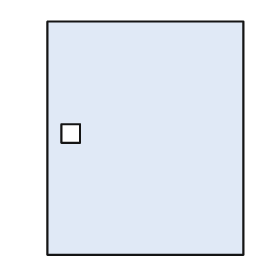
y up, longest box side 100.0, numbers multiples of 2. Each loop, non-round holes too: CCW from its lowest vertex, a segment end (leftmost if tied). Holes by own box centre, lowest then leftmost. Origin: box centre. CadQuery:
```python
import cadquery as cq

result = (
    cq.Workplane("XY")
    .moveTo(-42.0, -50.0)
    .lineTo(42.0, -50.0)
    .lineTo(42.0, 50.0)
    .lineTo(-42.0, 50.0)
    .close()
    .moveTo(-36.0, -2.0)
    .lineTo(-28.0, -2.0)
    .lineTo(-28.0, 6.0)
    .lineTo(-36.0, 6.0)
    .close()
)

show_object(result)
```